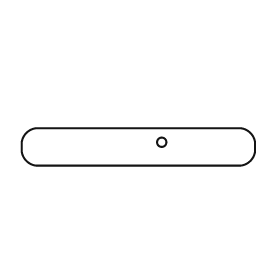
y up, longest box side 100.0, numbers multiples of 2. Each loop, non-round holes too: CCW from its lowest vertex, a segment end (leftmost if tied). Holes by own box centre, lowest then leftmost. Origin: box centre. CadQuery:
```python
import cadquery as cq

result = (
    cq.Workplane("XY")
    .moveTo(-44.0, -8.0)
    .lineTo(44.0, -8.0)
    .threePointArc((48.0, -6.0), (50.0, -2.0))
    .lineTo(50.0, 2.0)
    .threePointArc((48.0, 6.0), (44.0, 8.0))
    .lineTo(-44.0, 8.0)
    .threePointArc((-48.0, 6.0), (-50.0, 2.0))
    .lineTo(-50.0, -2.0)
    .threePointArc((-48.0, -6.0), (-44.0, -8.0))
    .close()
    .moveTo(10.0, 2.0)
    .circle(2.0)
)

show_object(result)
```